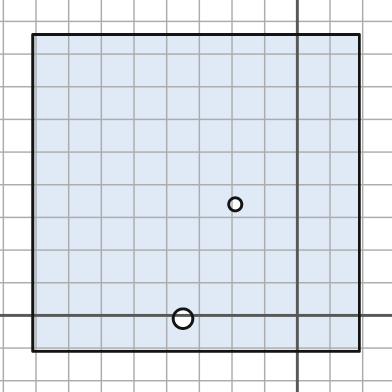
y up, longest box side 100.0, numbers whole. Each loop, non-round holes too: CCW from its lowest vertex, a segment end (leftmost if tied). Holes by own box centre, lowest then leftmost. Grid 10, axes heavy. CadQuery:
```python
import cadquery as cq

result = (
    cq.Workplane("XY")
    .moveTo(-81.0, -11.0)
    .lineTo(19.0, -11.0)
    .lineTo(19.0, 86.0)
    .lineTo(-81.0, 86.0)
    .close()
    .moveTo(-35.0, -1.0)
    .circle(3.0)
    .moveTo(-19.0, 34.0)
    .circle(2.0)
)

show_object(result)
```